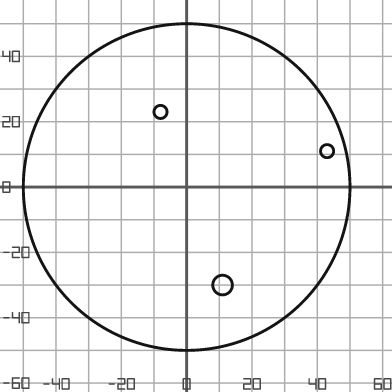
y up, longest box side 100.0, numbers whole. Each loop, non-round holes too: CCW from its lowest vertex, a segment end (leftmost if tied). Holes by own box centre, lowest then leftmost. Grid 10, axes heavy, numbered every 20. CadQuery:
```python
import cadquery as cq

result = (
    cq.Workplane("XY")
    .moveTo(0.0, 0.0)
    .circle(50.0)
    .moveTo(11.0, -30.0)
    .circle(3.0)
    .moveTo(43.0, 11.0)
    .circle(2.0)
    .moveTo(-8.0, 23.0)
    .circle(2.0)
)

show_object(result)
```